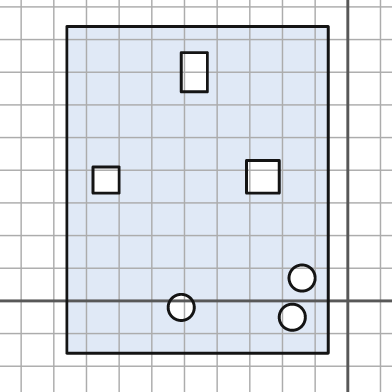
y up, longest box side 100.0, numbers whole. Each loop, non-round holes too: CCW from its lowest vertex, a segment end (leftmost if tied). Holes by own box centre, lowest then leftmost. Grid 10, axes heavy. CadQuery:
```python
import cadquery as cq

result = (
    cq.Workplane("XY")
    .moveTo(-86.0, -16.0)
    .lineTo(-6.0, -16.0)
    .lineTo(-6.0, 84.0)
    .lineTo(-86.0, 84.0)
    .close()
    .moveTo(-17.0, -5.0)
    .circle(4.0)
    .moveTo(-51.0, -2.0)
    .circle(4.0)
    .moveTo(-14.0, 7.0)
    .circle(4.0)
    .moveTo(-78.0, 33.0)
    .lineTo(-70.0, 33.0)
    .lineTo(-70.0, 41.0)
    .lineTo(-78.0, 41.0)
    .close()
    .moveTo(-31.0, 33.0)
    .lineTo(-21.0, 33.0)
    .lineTo(-21.0, 43.0)
    .lineTo(-31.0, 43.0)
    .close()
    .moveTo(-51.0, 64.0)
    .lineTo(-43.0, 64.0)
    .lineTo(-43.0, 76.0)
    .lineTo(-51.0, 76.0)
    .close()
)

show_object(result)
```